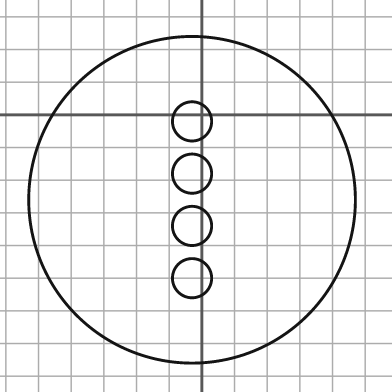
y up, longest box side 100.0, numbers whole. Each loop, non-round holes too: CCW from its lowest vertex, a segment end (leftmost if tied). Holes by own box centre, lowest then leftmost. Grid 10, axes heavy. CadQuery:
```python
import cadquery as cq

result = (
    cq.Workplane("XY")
    .moveTo(-3.0, -26.0)
    .circle(50.0)
    .moveTo(-3.0, -50.0)
    .circle(6.0)
    .moveTo(-3.0, -34.0)
    .circle(6.0)
    .moveTo(-3.0, -18.0)
    .circle(6.0)
    .moveTo(-3.0, -2.0)
    .circle(6.0)
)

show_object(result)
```